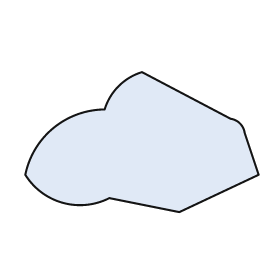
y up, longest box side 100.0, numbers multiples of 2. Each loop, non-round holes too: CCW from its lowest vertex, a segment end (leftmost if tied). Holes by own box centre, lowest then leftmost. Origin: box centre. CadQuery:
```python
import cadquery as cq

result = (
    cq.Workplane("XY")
    .moveTo(16.0, -30.0)
    .lineTo(50.0, -14.0)
    .lineTo(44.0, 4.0)
    .threePointArc((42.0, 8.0), (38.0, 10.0))
    .lineTo(0.0, 30.0)
    .threePointArc((-10.0, 24.0), (-16.0, 14.0))
    .threePointArc((-38.0, 6.0), (-50.0, -14.0))
    .threePointArc((-34.0, -26.0), (-14.0, -24.0))
    .close()
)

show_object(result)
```